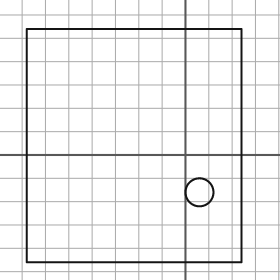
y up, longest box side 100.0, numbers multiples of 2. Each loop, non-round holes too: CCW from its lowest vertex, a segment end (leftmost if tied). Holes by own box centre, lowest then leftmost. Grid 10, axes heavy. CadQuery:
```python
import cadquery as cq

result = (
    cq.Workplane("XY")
    .moveTo(-68.0, -46.0)
    .lineTo(24.0, -46.0)
    .lineTo(24.0, 54.0)
    .lineTo(-68.0, 54.0)
    .close()
    .moveTo(6.0, -16.0)
    .circle(6.0)
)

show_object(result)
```